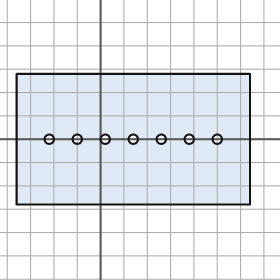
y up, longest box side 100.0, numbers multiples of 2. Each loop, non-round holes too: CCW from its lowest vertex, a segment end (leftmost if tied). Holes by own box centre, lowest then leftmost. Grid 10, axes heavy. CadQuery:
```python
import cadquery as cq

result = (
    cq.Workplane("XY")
    .moveTo(-36.0, -28.0)
    .lineTo(64.0, -28.0)
    .lineTo(64.0, 28.0)
    .lineTo(-36.0, 28.0)
    .close()
    .moveTo(-22.0, 0.0)
    .circle(2.0)
    .moveTo(-10.0, 0.0)
    .circle(2.0)
    .moveTo(2.0, 0.0)
    .circle(2.0)
    .moveTo(14.0, 0.0)
    .circle(2.0)
    .moveTo(26.0, 0.0)
    .circle(2.0)
    .moveTo(38.0, 0.0)
    .circle(2.0)
    .moveTo(50.0, 0.0)
    .circle(2.0)
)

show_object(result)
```